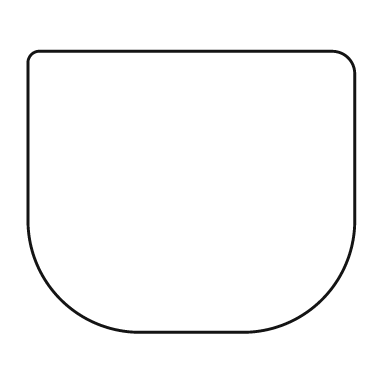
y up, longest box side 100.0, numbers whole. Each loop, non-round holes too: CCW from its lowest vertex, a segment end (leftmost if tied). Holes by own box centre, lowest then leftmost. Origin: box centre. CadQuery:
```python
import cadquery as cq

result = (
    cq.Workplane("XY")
    .moveTo(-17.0, -43.0)
    .lineTo(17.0, -43.0)
    .threePointArc((40.0, -33.0), (50.0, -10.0))
    .lineTo(50.0, 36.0)
    .threePointArc((48.0, 41.0), (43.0, 43.0))
    .lineTo(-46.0, 43.0)
    .threePointArc((-49.0, 42.0), (-50.0, 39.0))
    .lineTo(-50.0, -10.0)
    .threePointArc((-40.0, -33.0), (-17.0, -43.0))
    .close()
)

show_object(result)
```